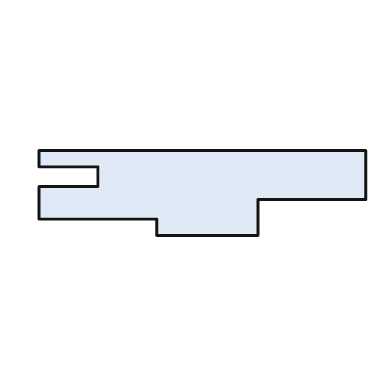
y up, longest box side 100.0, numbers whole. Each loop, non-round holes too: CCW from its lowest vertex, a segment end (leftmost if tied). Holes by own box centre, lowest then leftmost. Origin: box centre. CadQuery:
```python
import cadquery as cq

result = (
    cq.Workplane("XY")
    .moveTo(-14.0, -13.0)
    .lineTo(17.0, -13.0)
    .lineTo(17.0, -2.0)
    .lineTo(50.0, -2.0)
    .lineTo(50.0, 13.0)
    .lineTo(-50.0, 13.0)
    .lineTo(-50.0, 8.0)
    .lineTo(-32.0, 8.0)
    .lineTo(-32.0, 2.0)
    .lineTo(-50.0, 2.0)
    .lineTo(-50.0, -8.0)
    .lineTo(-14.0, -8.0)
    .close()
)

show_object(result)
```